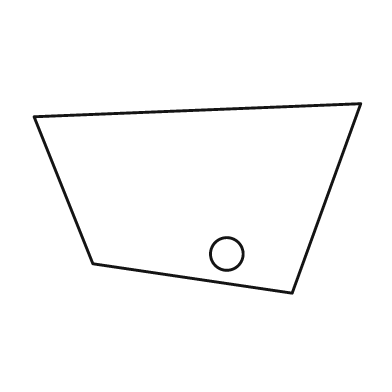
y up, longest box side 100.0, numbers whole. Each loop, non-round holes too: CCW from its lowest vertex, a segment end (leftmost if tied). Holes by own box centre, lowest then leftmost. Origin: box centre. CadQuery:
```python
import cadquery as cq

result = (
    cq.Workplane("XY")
    .moveTo(29.0, -29.0)
    .lineTo(50.0, 29.0)
    .lineTo(-50.0, 25.0)
    .lineTo(-32.0, -20.0)
    .close()
    .moveTo(9.0, -17.0)
    .circle(5.0)
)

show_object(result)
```